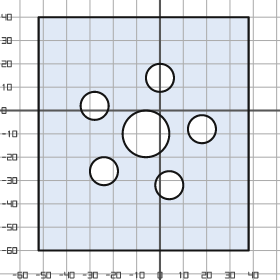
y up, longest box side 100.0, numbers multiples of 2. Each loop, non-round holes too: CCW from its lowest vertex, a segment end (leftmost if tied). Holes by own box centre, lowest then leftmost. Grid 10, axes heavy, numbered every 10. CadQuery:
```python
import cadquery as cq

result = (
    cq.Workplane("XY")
    .moveTo(-52.0, -60.0)
    .lineTo(38.0, -60.0)
    .lineTo(38.0, 40.0)
    .lineTo(-52.0, 40.0)
    .close()
    .moveTo(4.0, -32.0)
    .circle(6.0)
    .moveTo(-24.0, -26.0)
    .circle(6.0)
    .moveTo(-6.0, -10.0)
    .circle(10.0)
    .moveTo(18.0, -8.0)
    .circle(6.0)
    .moveTo(-28.0, 2.0)
    .circle(6.0)
    .moveTo(0.0, 14.0)
    .circle(6.0)
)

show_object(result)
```